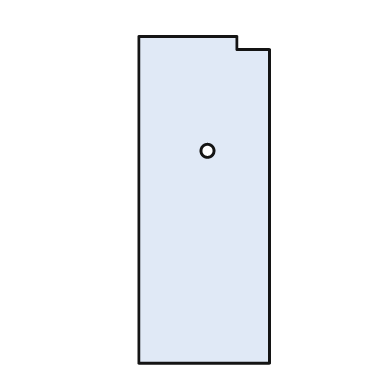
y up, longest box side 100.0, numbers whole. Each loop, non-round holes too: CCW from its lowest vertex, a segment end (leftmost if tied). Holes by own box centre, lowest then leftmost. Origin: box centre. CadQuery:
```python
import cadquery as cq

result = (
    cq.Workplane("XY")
    .moveTo(-20.0, -50.0)
    .lineTo(20.0, -50.0)
    .lineTo(20.0, 46.0)
    .lineTo(10.0, 46.0)
    .lineTo(10.0, 50.0)
    .lineTo(-20.0, 50.0)
    .close()
    .moveTo(1.0, 15.0)
    .circle(2.0)
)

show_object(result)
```